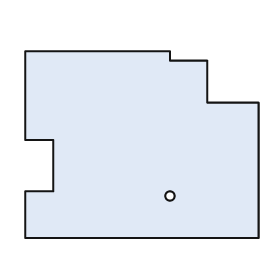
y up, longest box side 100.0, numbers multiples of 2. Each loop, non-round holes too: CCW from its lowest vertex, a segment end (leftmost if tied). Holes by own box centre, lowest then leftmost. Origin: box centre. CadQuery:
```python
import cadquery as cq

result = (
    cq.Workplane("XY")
    .moveTo(-50.0, -40.0)
    .lineTo(50.0, -40.0)
    .lineTo(50.0, 18.0)
    .lineTo(28.0, 18.0)
    .lineTo(28.0, 36.0)
    .lineTo(12.0, 36.0)
    .lineTo(12.0, 40.0)
    .lineTo(-50.0, 40.0)
    .lineTo(-50.0, 2.0)
    .lineTo(-38.0, 2.0)
    .lineTo(-38.0, -20.0)
    .lineTo(-50.0, -20.0)
    .close()
    .moveTo(12.0, -22.0)
    .circle(2.0)
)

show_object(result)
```